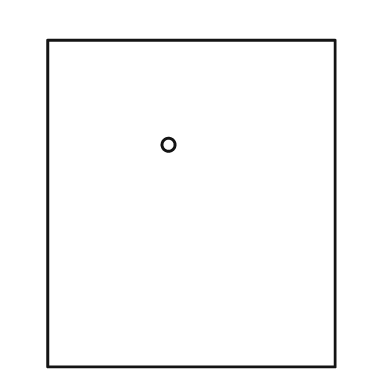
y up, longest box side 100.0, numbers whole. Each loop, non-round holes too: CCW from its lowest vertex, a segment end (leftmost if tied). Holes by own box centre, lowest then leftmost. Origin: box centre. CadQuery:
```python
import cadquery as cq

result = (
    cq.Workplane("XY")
    .moveTo(-44.0, -50.0)
    .lineTo(44.0, -50.0)
    .lineTo(44.0, 50.0)
    .lineTo(-44.0, 50.0)
    .close()
    .moveTo(-7.0, 18.0)
    .circle(2.0)
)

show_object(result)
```